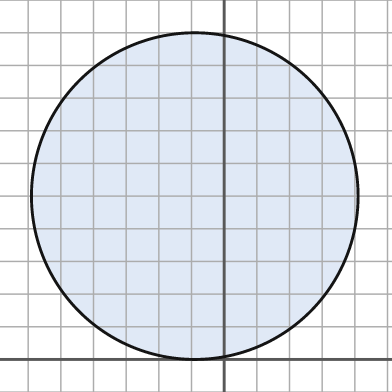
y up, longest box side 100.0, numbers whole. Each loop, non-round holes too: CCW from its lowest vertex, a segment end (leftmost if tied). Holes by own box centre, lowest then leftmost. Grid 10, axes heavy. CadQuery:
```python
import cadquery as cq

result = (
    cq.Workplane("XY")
    .moveTo(-9.0, 50.0)
    .circle(50.0)
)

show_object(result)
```